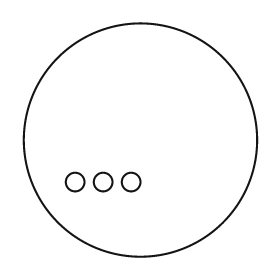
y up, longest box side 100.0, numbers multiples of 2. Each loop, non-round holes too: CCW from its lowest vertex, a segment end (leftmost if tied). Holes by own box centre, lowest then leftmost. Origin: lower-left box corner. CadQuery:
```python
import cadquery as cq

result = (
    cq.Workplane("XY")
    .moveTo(50.0, 50.0)
    .circle(50.0)
    .moveTo(22.0, 32.0)
    .circle(4.0)
    .moveTo(34.0, 32.0)
    .circle(4.0)
    .moveTo(46.0, 32.0)
    .circle(4.0)
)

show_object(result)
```